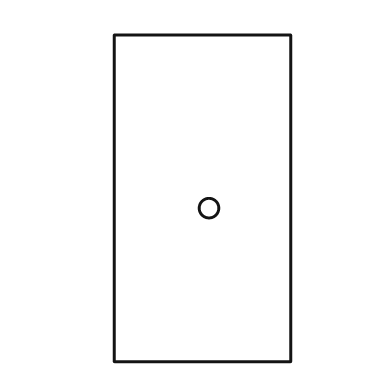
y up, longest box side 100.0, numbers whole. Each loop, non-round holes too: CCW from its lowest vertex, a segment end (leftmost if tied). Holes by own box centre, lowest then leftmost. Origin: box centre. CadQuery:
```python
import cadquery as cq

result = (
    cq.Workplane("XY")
    .moveTo(-27.0, -50.0)
    .lineTo(27.0, -50.0)
    .lineTo(27.0, 50.0)
    .lineTo(-27.0, 50.0)
    .close()
    .moveTo(2.0, -3.0)
    .circle(3.0)
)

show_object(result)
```